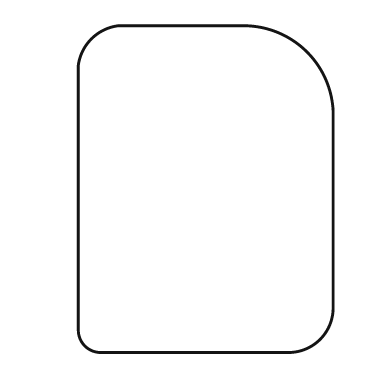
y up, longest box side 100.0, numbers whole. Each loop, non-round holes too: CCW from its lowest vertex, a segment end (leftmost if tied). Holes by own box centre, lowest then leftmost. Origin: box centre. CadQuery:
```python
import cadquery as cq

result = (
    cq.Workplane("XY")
    .moveTo(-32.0, -50.0)
    .lineTo(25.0, -50.0)
    .threePointArc((35.0, -46.0), (39.0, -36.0))
    .lineTo(39.0, 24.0)
    .threePointArc((31.0, 42.0), (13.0, 50.0))
    .lineTo(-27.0, 50.0)
    .threePointArc((-35.0, 46.0), (-39.0, 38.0))
    .lineTo(-39.0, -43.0)
    .threePointArc((-37.0, -48.0), (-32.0, -50.0))
    .close()
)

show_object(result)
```